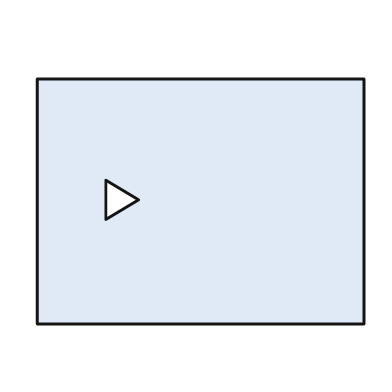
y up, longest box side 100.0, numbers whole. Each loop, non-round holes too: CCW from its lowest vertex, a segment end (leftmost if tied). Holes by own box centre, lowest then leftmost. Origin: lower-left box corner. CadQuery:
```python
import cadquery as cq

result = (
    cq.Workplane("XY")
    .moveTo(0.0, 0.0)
    .lineTo(100.0, 0.0)
    .lineTo(100.0, 75.0)
    .lineTo(0.0, 75.0)
    .close()
    .moveTo(21.0, 32.0)
    .lineTo(31.0, 38.0)
    .lineTo(21.0, 44.0)
    .close()
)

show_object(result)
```